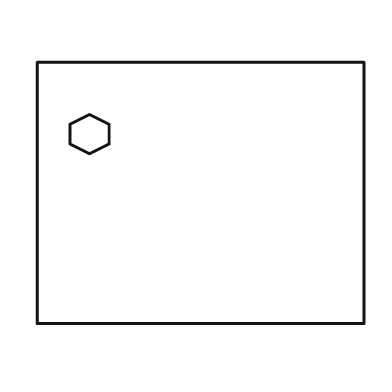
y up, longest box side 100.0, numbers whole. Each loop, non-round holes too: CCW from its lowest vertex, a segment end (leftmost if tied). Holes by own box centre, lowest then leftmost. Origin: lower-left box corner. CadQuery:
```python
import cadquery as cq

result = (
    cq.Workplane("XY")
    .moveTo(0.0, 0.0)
    .lineTo(100.0, 0.0)
    .lineTo(100.0, 80.0)
    .lineTo(0.0, 80.0)
    .close()
    .moveTo(16.0, 52.0)
    .lineTo(22.0, 55.0)
    .lineTo(22.0, 61.0)
    .lineTo(16.0, 64.0)
    .lineTo(10.0, 61.0)
    .lineTo(10.0, 55.0)
    .close()
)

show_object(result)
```